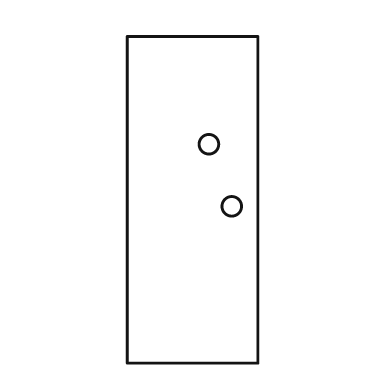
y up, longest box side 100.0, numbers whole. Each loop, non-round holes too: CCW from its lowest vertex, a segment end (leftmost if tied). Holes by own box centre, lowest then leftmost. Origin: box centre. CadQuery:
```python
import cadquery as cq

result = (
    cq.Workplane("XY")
    .moveTo(-20.0, -50.0)
    .lineTo(20.0, -50.0)
    .lineTo(20.0, 50.0)
    .lineTo(-20.0, 50.0)
    .close()
    .moveTo(12.0, -2.0)
    .circle(3.0)
    .moveTo(5.0, 17.0)
    .circle(3.0)
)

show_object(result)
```